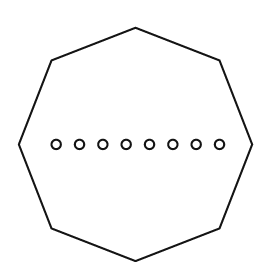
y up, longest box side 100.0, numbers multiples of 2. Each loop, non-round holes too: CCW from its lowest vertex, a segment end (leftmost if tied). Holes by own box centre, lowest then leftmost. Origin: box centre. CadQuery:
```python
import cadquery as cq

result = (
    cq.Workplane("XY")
    .moveTo(0.0, -50.0)
    .lineTo(36.0, -36.0)
    .lineTo(50.0, 0.0)
    .lineTo(36.0, 36.0)
    .lineTo(0.0, 50.0)
    .lineTo(-36.0, 36.0)
    .lineTo(-50.0, 0.0)
    .lineTo(-36.0, -36.0)
    .close()
    .moveTo(-34.0, 0.0)
    .circle(2.0)
    .moveTo(-24.0, 0.0)
    .circle(2.0)
    .moveTo(-14.0, 0.0)
    .circle(2.0)
    .moveTo(-4.0, 0.0)
    .circle(2.0)
    .moveTo(6.0, 0.0)
    .circle(2.0)
    .moveTo(16.0, 0.0)
    .circle(2.0)
    .moveTo(26.0, 0.0)
    .circle(2.0)
    .moveTo(36.0, 0.0)
    .circle(2.0)
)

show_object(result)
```